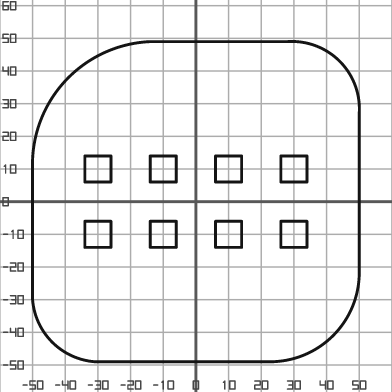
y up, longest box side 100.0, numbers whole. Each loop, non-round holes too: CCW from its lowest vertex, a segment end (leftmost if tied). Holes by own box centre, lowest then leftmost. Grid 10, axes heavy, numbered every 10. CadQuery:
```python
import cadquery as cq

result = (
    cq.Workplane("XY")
    .moveTo(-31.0, -49.0)
    .lineTo(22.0, -49.0)
    .threePointArc((42.0, -41.0), (50.0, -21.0))
    .lineTo(50.0, 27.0)
    .threePointArc((44.0, 43.0), (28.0, 49.0))
    .lineTo(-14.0, 49.0)
    .threePointArc((-39.0, 38.0), (-50.0, 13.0))
    .lineTo(-50.0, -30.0)
    .threePointArc((-44.0, -43.0), (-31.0, -49.0))
    .close()
    .moveTo(-34.0, -14.0)
    .lineTo(-26.0, -14.0)
    .lineTo(-26.0, -6.0)
    .lineTo(-34.0, -6.0)
    .close()
    .moveTo(-14.0, -14.0)
    .lineTo(-6.0, -14.0)
    .lineTo(-6.0, -6.0)
    .lineTo(-14.0, -6.0)
    .close()
    .moveTo(6.0, -14.0)
    .lineTo(14.0, -14.0)
    .lineTo(14.0, -6.0)
    .lineTo(6.0, -6.0)
    .close()
    .moveTo(26.0, -14.0)
    .lineTo(34.0, -14.0)
    .lineTo(34.0, -6.0)
    .lineTo(26.0, -6.0)
    .close()
    .moveTo(-34.0, 6.0)
    .lineTo(-26.0, 6.0)
    .lineTo(-26.0, 14.0)
    .lineTo(-34.0, 14.0)
    .close()
    .moveTo(-14.0, 6.0)
    .lineTo(-6.0, 6.0)
    .lineTo(-6.0, 14.0)
    .lineTo(-14.0, 14.0)
    .close()
    .moveTo(6.0, 6.0)
    .lineTo(14.0, 6.0)
    .lineTo(14.0, 14.0)
    .lineTo(6.0, 14.0)
    .close()
    .moveTo(26.0, 6.0)
    .lineTo(34.0, 6.0)
    .lineTo(34.0, 14.0)
    .lineTo(26.0, 14.0)
    .close()
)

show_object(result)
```